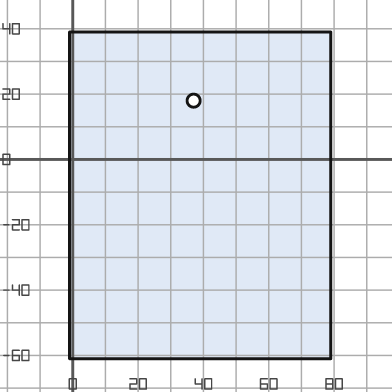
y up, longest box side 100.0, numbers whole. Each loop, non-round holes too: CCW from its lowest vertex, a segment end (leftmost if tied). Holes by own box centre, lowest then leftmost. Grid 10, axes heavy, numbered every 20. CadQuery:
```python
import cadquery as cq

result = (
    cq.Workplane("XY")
    .moveTo(-1.0, -61.0)
    .lineTo(79.0, -61.0)
    .lineTo(79.0, 39.0)
    .lineTo(-1.0, 39.0)
    .close()
    .moveTo(37.0, 18.0)
    .circle(2.0)
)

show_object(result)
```